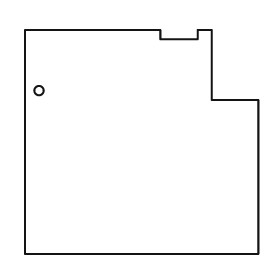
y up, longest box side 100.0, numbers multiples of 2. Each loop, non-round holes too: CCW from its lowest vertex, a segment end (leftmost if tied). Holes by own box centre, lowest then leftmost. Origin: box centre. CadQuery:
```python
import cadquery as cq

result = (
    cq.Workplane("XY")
    .moveTo(-50.0, -48.0)
    .lineTo(50.0, -48.0)
    .lineTo(50.0, 18.0)
    .lineTo(30.0, 18.0)
    .lineTo(30.0, 48.0)
    .lineTo(24.0, 48.0)
    .lineTo(24.0, 44.0)
    .lineTo(8.0, 44.0)
    .lineTo(8.0, 48.0)
    .lineTo(-50.0, 48.0)
    .close()
    .moveTo(-44.0, 22.0)
    .circle(2.0)
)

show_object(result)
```